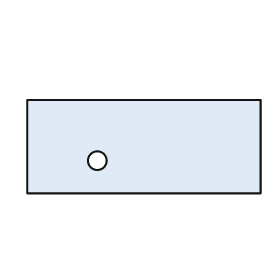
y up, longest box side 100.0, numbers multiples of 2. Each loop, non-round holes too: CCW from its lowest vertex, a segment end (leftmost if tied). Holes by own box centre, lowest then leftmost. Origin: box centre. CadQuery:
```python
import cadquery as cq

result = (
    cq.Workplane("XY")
    .moveTo(-50.0, -20.0)
    .lineTo(50.0, -20.0)
    .lineTo(50.0, 20.0)
    .lineTo(-50.0, 20.0)
    .close()
    .moveTo(-20.0, -6.0)
    .circle(4.0)
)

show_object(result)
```